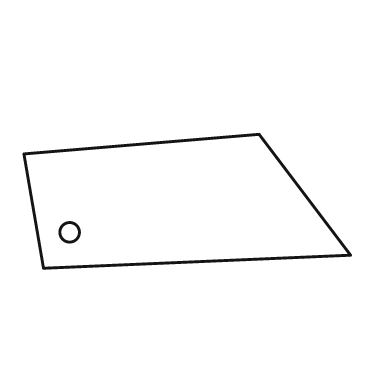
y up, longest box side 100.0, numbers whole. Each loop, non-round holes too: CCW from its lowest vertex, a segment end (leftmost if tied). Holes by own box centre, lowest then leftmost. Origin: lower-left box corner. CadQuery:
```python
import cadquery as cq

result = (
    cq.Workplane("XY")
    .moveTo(6.0, 0.0)
    .lineTo(100.0, 4.0)
    .lineTo(72.0, 41.0)
    .lineTo(0.0, 35.0)
    .close()
    .moveTo(14.0, 11.0)
    .circle(3.0)
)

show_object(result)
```